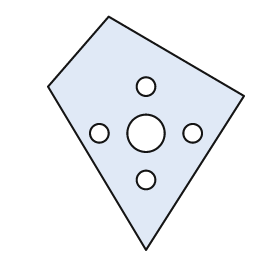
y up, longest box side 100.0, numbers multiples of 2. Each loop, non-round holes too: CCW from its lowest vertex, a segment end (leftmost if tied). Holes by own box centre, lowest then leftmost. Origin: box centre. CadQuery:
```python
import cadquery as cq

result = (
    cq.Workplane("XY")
    .moveTo(0.0, -50.0)
    .lineTo(42.0, 16.0)
    .lineTo(-16.0, 50.0)
    .lineTo(-42.0, 20.0)
    .close()
    .moveTo(0.0, -20.0)
    .circle(4.0)
    .moveTo(-20.0, 0.0)
    .circle(4.0)
    .moveTo(0.0, 0.0)
    .circle(8.0)
    .moveTo(20.0, 0.0)
    .circle(4.0)
    .moveTo(0.0, 20.0)
    .circle(4.0)
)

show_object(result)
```